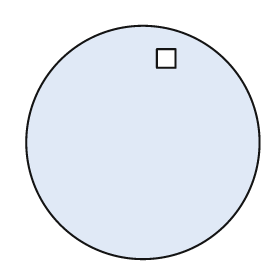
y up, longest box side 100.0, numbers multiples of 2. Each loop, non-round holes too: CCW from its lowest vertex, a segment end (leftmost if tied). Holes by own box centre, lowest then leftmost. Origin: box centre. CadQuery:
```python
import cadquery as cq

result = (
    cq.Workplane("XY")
    .moveTo(0.0, 0.0)
    .circle(50.0)
    .moveTo(6.0, 32.0)
    .lineTo(14.0, 32.0)
    .lineTo(14.0, 40.0)
    .lineTo(6.0, 40.0)
    .close()
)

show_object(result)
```